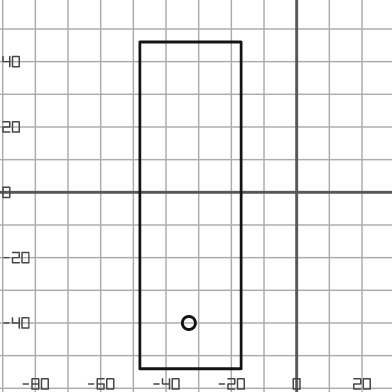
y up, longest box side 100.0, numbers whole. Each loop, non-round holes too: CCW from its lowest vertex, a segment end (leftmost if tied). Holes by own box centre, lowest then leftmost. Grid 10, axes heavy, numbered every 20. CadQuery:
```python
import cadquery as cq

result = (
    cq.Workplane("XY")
    .moveTo(-48.0, -54.0)
    .lineTo(-17.0, -54.0)
    .lineTo(-17.0, 46.0)
    .lineTo(-48.0, 46.0)
    .close()
    .moveTo(-33.0, -40.0)
    .circle(2.0)
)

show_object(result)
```